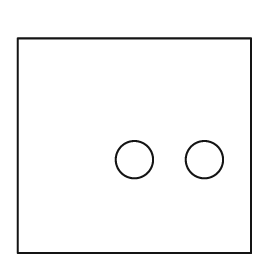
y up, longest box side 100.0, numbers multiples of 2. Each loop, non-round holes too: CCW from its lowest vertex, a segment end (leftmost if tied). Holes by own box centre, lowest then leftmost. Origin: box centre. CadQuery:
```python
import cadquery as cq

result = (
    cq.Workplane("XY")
    .moveTo(-50.0, -46.0)
    .lineTo(50.0, -46.0)
    .lineTo(50.0, 46.0)
    .lineTo(-50.0, 46.0)
    .close()
    .moveTo(0.0, -6.0)
    .circle(8.0)
    .moveTo(30.0, -6.0)
    .circle(8.0)
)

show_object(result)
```